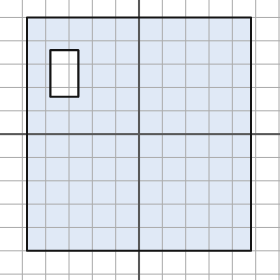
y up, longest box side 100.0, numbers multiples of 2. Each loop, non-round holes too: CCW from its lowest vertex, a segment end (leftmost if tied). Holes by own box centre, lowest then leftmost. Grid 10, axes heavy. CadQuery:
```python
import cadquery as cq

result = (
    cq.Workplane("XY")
    .moveTo(-48.0, -50.0)
    .lineTo(48.0, -50.0)
    .lineTo(48.0, 50.0)
    .lineTo(-48.0, 50.0)
    .close()
    .moveTo(-38.0, 16.0)
    .lineTo(-26.0, 16.0)
    .lineTo(-26.0, 36.0)
    .lineTo(-38.0, 36.0)
    .close()
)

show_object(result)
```